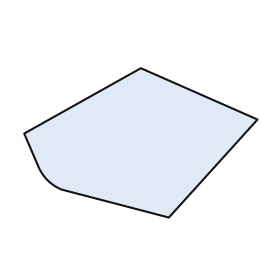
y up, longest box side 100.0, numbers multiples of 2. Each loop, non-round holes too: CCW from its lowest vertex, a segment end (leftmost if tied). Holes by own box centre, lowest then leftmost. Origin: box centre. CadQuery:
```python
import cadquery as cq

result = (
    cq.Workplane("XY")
    .moveTo(12.0, -32.0)
    .lineTo(50.0, 10.0)
    .lineTo(0.0, 32.0)
    .lineTo(-50.0, 4.0)
    .lineTo(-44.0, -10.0)
    .threePointArc((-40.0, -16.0), (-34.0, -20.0))
    .close()
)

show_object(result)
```